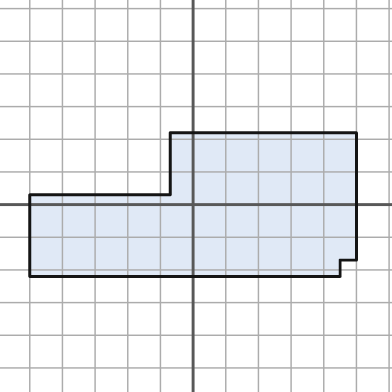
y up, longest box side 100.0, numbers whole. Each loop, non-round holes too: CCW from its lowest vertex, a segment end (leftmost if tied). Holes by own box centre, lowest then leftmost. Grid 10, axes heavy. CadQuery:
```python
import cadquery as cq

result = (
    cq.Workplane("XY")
    .moveTo(-50.0, -22.0)
    .lineTo(45.0, -22.0)
    .lineTo(45.0, -17.0)
    .lineTo(50.0, -17.0)
    .lineTo(50.0, 22.0)
    .lineTo(-7.0, 22.0)
    .lineTo(-7.0, 3.0)
    .lineTo(-50.0, 3.0)
    .close()
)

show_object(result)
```